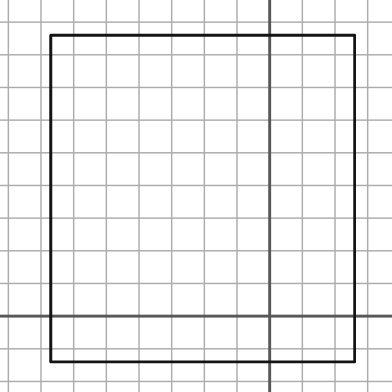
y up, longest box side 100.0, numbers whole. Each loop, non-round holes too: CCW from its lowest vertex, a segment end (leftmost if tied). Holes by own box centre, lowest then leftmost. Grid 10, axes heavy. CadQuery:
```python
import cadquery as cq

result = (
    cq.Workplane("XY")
    .moveTo(-67.0, -14.0)
    .lineTo(26.0, -14.0)
    .lineTo(26.0, 86.0)
    .lineTo(-67.0, 86.0)
    .close()
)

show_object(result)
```